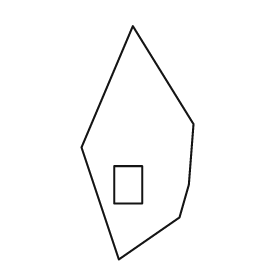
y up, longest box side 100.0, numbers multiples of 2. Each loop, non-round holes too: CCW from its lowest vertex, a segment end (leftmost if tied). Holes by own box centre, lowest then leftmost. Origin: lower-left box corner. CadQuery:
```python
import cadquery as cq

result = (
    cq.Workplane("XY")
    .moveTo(16.0, 0.0)
    .lineTo(42.0, 18.0)
    .lineTo(46.0, 32.0)
    .lineTo(48.0, 58.0)
    .lineTo(22.0, 100.0)
    .lineTo(0.0, 48.0)
    .close()
    .moveTo(14.0, 24.0)
    .lineTo(26.0, 24.0)
    .lineTo(26.0, 40.0)
    .lineTo(14.0, 40.0)
    .close()
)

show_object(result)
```